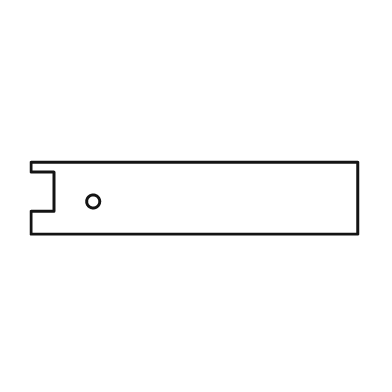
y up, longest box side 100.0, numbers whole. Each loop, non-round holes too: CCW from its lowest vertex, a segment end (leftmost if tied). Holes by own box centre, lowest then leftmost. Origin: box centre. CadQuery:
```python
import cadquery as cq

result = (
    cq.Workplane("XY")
    .moveTo(-50.0, -11.0)
    .lineTo(50.0, -11.0)
    .lineTo(50.0, 11.0)
    .lineTo(-50.0, 11.0)
    .lineTo(-50.0, 8.0)
    .lineTo(-43.0, 8.0)
    .lineTo(-43.0, -4.0)
    .lineTo(-50.0, -4.0)
    .close()
    .moveTo(-31.0, -1.0)
    .circle(2.0)
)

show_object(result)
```